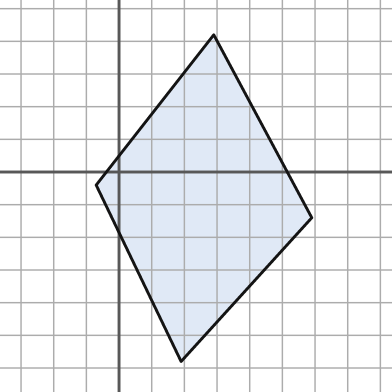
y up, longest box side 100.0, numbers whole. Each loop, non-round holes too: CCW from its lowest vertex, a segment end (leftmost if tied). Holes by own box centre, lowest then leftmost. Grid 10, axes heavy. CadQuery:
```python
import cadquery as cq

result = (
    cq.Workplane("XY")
    .moveTo(19.0, -58.0)
    .lineTo(59.0, -14.0)
    .lineTo(29.0, 42.0)
    .lineTo(-7.0, -4.0)
    .close()
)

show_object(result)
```